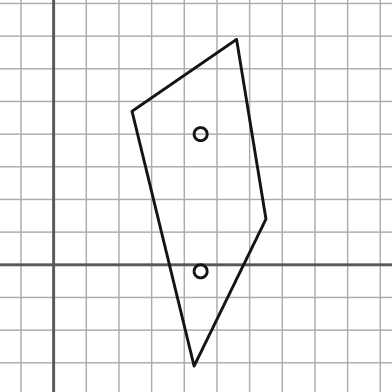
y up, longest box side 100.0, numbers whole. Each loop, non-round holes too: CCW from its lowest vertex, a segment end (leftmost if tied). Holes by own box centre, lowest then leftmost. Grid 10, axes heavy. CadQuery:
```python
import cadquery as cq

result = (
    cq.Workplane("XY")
    .moveTo(43.0, -31.0)
    .lineTo(65.0, 14.0)
    .lineTo(56.0, 69.0)
    .lineTo(24.0, 47.0)
    .close()
    .moveTo(45.0, -2.0)
    .circle(2.0)
    .moveTo(45.0, 40.0)
    .circle(2.0)
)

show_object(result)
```